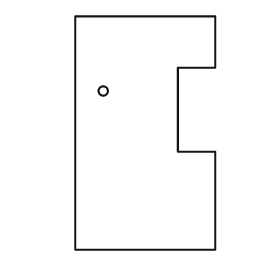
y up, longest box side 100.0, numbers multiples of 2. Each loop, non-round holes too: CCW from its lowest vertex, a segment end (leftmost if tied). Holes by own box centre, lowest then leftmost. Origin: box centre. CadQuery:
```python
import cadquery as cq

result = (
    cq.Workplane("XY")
    .moveTo(-30.0, -50.0)
    .lineTo(30.0, -50.0)
    .lineTo(30.0, -8.0)
    .lineTo(14.0, -8.0)
    .lineTo(14.0, 28.0)
    .lineTo(30.0, 28.0)
    .lineTo(30.0, 50.0)
    .lineTo(-30.0, 50.0)
    .close()
    .moveTo(-18.0, 18.0)
    .circle(2.0)
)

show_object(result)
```